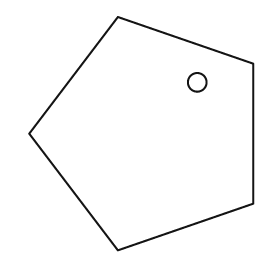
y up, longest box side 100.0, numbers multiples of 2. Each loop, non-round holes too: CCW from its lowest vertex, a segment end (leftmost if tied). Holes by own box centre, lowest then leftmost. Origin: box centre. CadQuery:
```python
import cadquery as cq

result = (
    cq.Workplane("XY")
    .moveTo(-10.0, -50.0)
    .lineTo(48.0, -30.0)
    .lineTo(48.0, 30.0)
    .lineTo(-10.0, 50.0)
    .lineTo(-48.0, 0.0)
    .close()
    .moveTo(24.0, 22.0)
    .circle(4.0)
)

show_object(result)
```